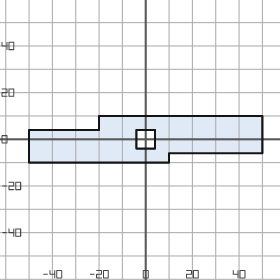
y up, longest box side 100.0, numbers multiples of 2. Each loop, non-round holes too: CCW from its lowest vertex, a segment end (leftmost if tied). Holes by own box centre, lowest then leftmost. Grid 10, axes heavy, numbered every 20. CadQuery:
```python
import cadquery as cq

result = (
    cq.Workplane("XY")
    .moveTo(-50.0, -10.0)
    .lineTo(10.0, -10.0)
    .lineTo(10.0, -6.0)
    .lineTo(50.0, -6.0)
    .lineTo(50.0, 10.0)
    .lineTo(-20.0, 10.0)
    .lineTo(-20.0, 4.0)
    .lineTo(-50.0, 4.0)
    .close()
    .moveTo(-4.0, -4.0)
    .lineTo(4.0, -4.0)
    .lineTo(4.0, 4.0)
    .lineTo(-4.0, 4.0)
    .close()
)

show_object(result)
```